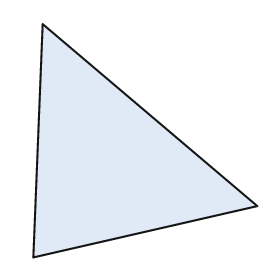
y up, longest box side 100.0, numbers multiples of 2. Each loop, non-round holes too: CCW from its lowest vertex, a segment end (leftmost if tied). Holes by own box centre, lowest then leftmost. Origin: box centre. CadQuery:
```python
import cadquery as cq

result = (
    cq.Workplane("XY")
    .moveTo(-48.0, -50.0)
    .lineTo(48.0, -28.0)
    .lineTo(-44.0, 50.0)
    .close()
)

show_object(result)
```